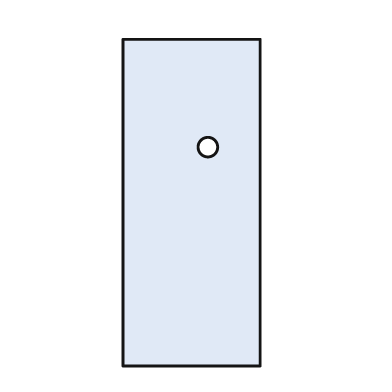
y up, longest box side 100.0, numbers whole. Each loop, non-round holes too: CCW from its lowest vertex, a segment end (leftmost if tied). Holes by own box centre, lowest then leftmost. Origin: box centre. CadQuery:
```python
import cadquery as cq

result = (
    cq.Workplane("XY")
    .moveTo(-21.0, -50.0)
    .lineTo(21.0, -50.0)
    .lineTo(21.0, 50.0)
    .lineTo(-21.0, 50.0)
    .close()
    .moveTo(5.0, 17.0)
    .circle(3.0)
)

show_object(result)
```